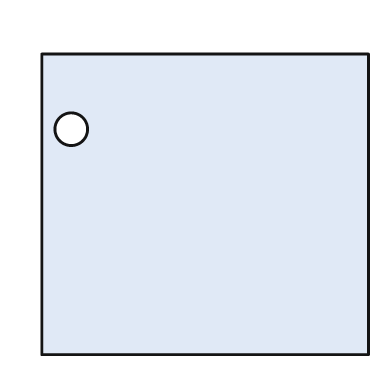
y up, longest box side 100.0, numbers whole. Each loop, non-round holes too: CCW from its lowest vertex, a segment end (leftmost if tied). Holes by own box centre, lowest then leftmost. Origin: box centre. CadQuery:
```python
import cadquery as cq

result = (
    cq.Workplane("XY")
    .moveTo(-50.0, -46.0)
    .lineTo(50.0, -46.0)
    .lineTo(50.0, 46.0)
    .lineTo(-50.0, 46.0)
    .close()
    .moveTo(-41.0, 23.0)
    .circle(5.0)
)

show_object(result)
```